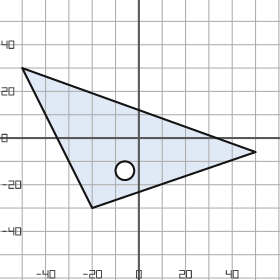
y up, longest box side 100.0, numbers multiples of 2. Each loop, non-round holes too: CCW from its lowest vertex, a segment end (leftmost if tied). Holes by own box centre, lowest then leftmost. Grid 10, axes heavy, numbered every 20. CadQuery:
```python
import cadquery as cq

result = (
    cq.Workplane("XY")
    .moveTo(-20.0, -30.0)
    .lineTo(50.0, -6.0)
    .lineTo(-50.0, 30.0)
    .close()
    .moveTo(-6.0, -14.0)
    .circle(4.0)
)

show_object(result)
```